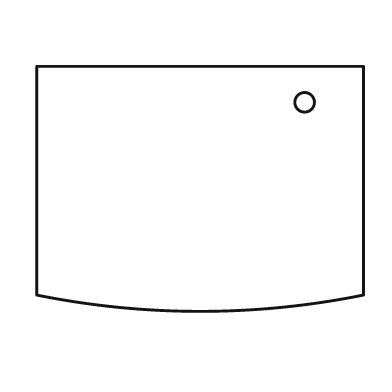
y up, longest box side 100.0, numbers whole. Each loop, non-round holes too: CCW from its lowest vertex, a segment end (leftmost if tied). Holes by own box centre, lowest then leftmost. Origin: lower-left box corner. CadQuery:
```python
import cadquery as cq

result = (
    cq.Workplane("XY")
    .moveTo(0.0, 5.0)
    .threePointArc((50.0, 0.0), (100.0, 5.0))
    .lineTo(100.0, 75.0)
    .lineTo(0.0, 75.0)
    .close()
    .moveTo(82.0, 64.0)
    .circle(3.0)
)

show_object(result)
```